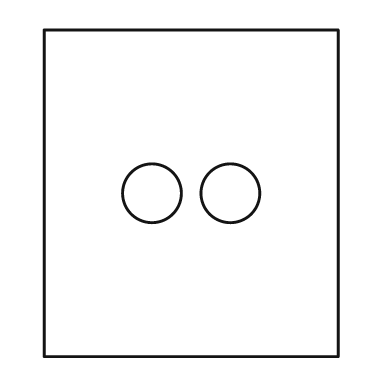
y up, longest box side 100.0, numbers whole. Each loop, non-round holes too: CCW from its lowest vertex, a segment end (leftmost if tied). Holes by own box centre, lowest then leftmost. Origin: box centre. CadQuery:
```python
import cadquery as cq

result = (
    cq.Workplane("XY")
    .moveTo(-45.0, -50.0)
    .lineTo(45.0, -50.0)
    .lineTo(45.0, 50.0)
    .lineTo(-45.0, 50.0)
    .close()
    .moveTo(-12.0, 0.0)
    .circle(9.0)
    .moveTo(12.0, 0.0)
    .circle(9.0)
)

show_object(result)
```